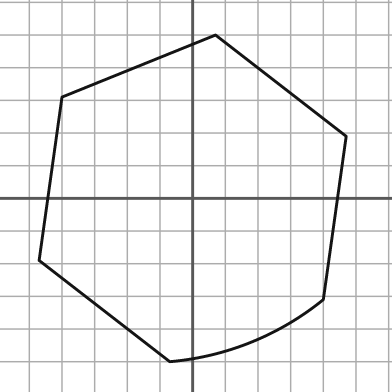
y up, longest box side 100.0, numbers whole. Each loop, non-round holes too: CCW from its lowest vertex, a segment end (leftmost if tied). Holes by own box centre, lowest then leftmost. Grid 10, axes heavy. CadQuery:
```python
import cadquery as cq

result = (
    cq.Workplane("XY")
    .moveTo(-7.0, -50.0)
    .threePointArc((18.0, -44.0), (40.0, -31.0))
    .lineTo(47.0, 19.0)
    .lineTo(7.0, 50.0)
    .lineTo(-40.0, 31.0)
    .lineTo(-47.0, -19.0)
    .close()
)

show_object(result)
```